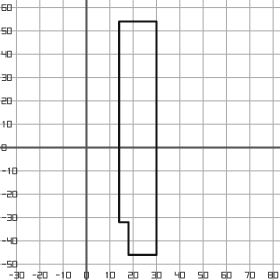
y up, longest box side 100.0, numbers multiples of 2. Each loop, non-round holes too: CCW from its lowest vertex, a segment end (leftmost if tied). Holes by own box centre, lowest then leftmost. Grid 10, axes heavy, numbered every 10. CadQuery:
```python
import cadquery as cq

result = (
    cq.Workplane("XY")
    .moveTo(18.0, -46.0)
    .lineTo(30.0, -46.0)
    .lineTo(30.0, 54.0)
    .lineTo(14.0, 54.0)
    .lineTo(14.0, -32.0)
    .lineTo(18.0, -32.0)
    .close()
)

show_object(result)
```